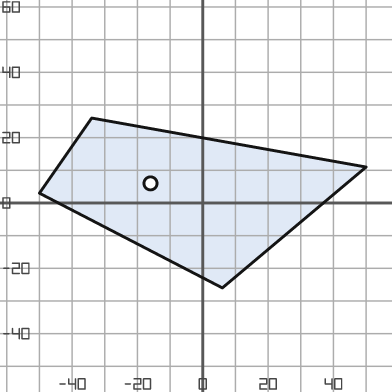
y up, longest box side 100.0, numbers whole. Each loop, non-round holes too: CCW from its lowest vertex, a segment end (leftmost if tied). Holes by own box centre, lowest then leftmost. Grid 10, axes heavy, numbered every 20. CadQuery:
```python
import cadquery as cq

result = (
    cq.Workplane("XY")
    .moveTo(6.0, -26.0)
    .lineTo(50.0, 11.0)
    .lineTo(-34.0, 26.0)
    .lineTo(-50.0, 3.0)
    .close()
    .moveTo(-16.0, 6.0)
    .circle(2.0)
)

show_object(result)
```